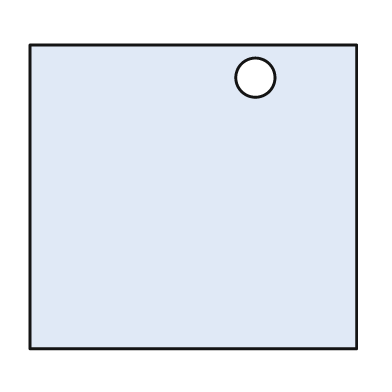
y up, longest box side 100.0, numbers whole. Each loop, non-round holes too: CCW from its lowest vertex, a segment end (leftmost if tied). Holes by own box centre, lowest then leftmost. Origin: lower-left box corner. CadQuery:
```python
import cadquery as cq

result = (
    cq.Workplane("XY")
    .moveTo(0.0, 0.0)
    .lineTo(100.0, 0.0)
    .lineTo(100.0, 93.0)
    .lineTo(0.0, 93.0)
    .close()
    .moveTo(69.0, 83.0)
    .circle(6.0)
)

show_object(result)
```